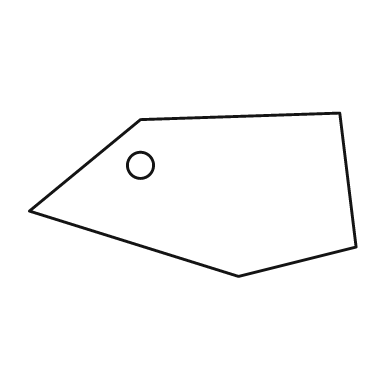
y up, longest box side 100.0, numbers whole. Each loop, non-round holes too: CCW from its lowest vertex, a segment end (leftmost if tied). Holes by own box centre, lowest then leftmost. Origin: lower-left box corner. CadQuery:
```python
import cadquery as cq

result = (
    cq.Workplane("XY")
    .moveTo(64.0, 0.0)
    .lineTo(100.0, 9.0)
    .lineTo(95.0, 50.0)
    .lineTo(34.0, 48.0)
    .lineTo(0.0, 20.0)
    .close()
    .moveTo(34.0, 34.0)
    .circle(4.0)
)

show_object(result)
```